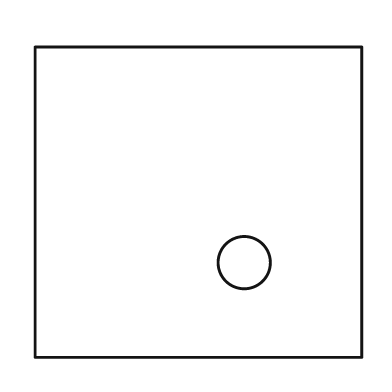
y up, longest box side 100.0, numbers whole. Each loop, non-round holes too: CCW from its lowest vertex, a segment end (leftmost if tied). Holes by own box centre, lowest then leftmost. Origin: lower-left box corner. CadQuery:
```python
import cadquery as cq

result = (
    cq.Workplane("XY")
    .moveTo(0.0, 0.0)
    .lineTo(100.0, 0.0)
    .lineTo(100.0, 95.0)
    .lineTo(0.0, 95.0)
    .close()
    .moveTo(64.0, 29.0)
    .circle(8.0)
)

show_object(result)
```